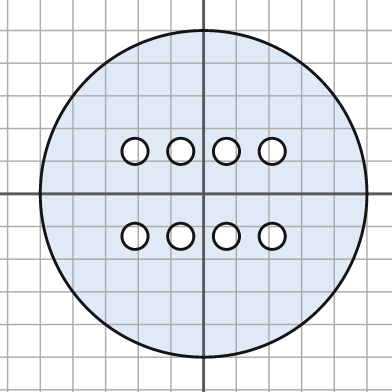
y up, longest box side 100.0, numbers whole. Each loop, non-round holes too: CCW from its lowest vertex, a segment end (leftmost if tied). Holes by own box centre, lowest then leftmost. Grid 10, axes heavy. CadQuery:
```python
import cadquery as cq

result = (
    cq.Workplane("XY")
    .moveTo(0.0, 0.0)
    .circle(50.0)
    .moveTo(-21.0, -13.0)
    .circle(4.0)
    .moveTo(-7.0, -13.0)
    .circle(4.0)
    .moveTo(7.0, -13.0)
    .circle(4.0)
    .moveTo(21.0, -13.0)
    .circle(4.0)
    .moveTo(-21.0, 13.0)
    .circle(4.0)
    .moveTo(-7.0, 13.0)
    .circle(4.0)
    .moveTo(7.0, 13.0)
    .circle(4.0)
    .moveTo(21.0, 13.0)
    .circle(4.0)
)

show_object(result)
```